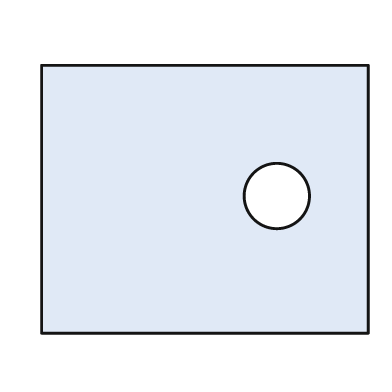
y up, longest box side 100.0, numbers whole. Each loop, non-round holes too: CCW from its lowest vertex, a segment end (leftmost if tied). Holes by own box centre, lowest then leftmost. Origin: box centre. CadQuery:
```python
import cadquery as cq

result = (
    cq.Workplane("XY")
    .moveTo(-50.0, -41.0)
    .lineTo(50.0, -41.0)
    .lineTo(50.0, 41.0)
    .lineTo(-50.0, 41.0)
    .close()
    .moveTo(22.0, 1.0)
    .circle(10.0)
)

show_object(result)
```